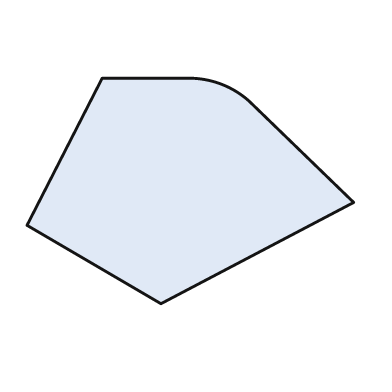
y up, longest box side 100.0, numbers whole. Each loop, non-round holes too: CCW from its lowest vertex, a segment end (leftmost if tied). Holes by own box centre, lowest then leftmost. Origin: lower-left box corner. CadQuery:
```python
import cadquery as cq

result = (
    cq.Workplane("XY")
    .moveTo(41.0, 0.0)
    .lineTo(100.0, 31.0)
    .lineTo(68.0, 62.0)
    .threePointArc((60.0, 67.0), (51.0, 69.0))
    .lineTo(23.0, 69.0)
    .lineTo(0.0, 24.0)
    .close()
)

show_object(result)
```